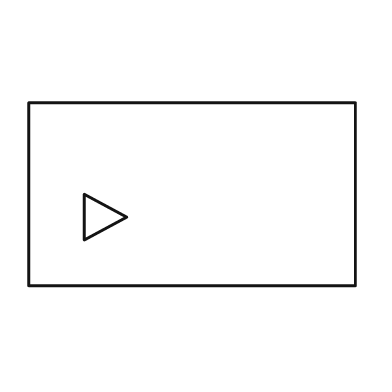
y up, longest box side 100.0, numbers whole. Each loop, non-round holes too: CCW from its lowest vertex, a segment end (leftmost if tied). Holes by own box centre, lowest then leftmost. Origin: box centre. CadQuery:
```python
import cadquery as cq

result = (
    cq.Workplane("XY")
    .moveTo(-50.0, -28.0)
    .lineTo(50.0, -28.0)
    .lineTo(50.0, 28.0)
    .lineTo(-50.0, 28.0)
    .close()
    .moveTo(-33.0, -14.0)
    .lineTo(-20.0, -7.0)
    .lineTo(-33.0, 0.0)
    .close()
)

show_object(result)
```